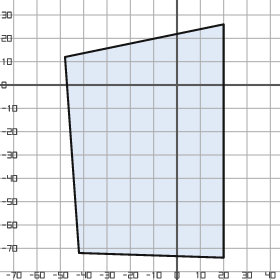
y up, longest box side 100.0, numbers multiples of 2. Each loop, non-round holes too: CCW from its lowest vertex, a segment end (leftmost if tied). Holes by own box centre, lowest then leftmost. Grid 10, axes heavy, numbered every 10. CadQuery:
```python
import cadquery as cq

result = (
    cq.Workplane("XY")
    .moveTo(20.0, -74.0)
    .lineTo(20.0, 26.0)
    .lineTo(-48.0, 12.0)
    .lineTo(-42.0, -72.0)
    .close()
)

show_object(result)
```